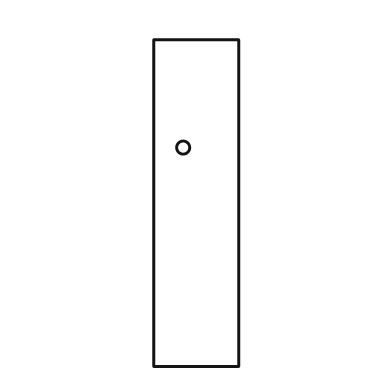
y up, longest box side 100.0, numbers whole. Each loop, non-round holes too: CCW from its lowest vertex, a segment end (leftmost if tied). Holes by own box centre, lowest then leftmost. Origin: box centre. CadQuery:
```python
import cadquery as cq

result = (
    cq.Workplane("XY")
    .moveTo(-13.0, -50.0)
    .lineTo(13.0, -50.0)
    .lineTo(13.0, 50.0)
    .lineTo(-13.0, 50.0)
    .close()
    .moveTo(-4.0, 17.0)
    .circle(2.0)
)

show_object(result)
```